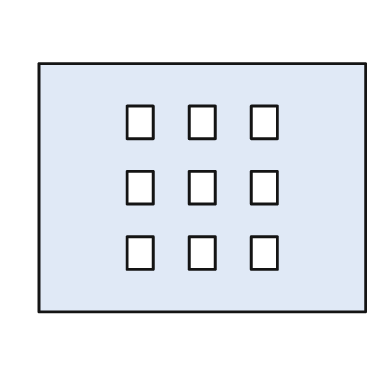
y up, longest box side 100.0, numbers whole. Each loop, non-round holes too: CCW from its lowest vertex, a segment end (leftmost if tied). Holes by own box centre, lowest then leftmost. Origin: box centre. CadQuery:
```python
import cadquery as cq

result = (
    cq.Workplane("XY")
    .moveTo(-50.0, -38.0)
    .lineTo(50.0, -38.0)
    .lineTo(50.0, 38.0)
    .lineTo(-50.0, 38.0)
    .close()
    .moveTo(-23.0, -25.0)
    .lineTo(-15.0, -25.0)
    .lineTo(-15.0, -15.0)
    .lineTo(-23.0, -15.0)
    .close()
    .moveTo(-4.0, -25.0)
    .lineTo(4.0, -25.0)
    .lineTo(4.0, -15.0)
    .lineTo(-4.0, -15.0)
    .close()
    .moveTo(15.0, -25.0)
    .lineTo(23.0, -25.0)
    .lineTo(23.0, -15.0)
    .lineTo(15.0, -15.0)
    .close()
    .moveTo(-23.0, -5.0)
    .lineTo(-15.0, -5.0)
    .lineTo(-15.0, 5.0)
    .lineTo(-23.0, 5.0)
    .close()
    .moveTo(-4.0, -5.0)
    .lineTo(4.0, -5.0)
    .lineTo(4.0, 5.0)
    .lineTo(-4.0, 5.0)
    .close()
    .moveTo(15.0, -5.0)
    .lineTo(23.0, -5.0)
    .lineTo(23.0, 5.0)
    .lineTo(15.0, 5.0)
    .close()
    .moveTo(-23.0, 15.0)
    .lineTo(-15.0, 15.0)
    .lineTo(-15.0, 25.0)
    .lineTo(-23.0, 25.0)
    .close()
    .moveTo(-4.0, 15.0)
    .lineTo(4.0, 15.0)
    .lineTo(4.0, 25.0)
    .lineTo(-4.0, 25.0)
    .close()
    .moveTo(15.0, 15.0)
    .lineTo(23.0, 15.0)
    .lineTo(23.0, 25.0)
    .lineTo(15.0, 25.0)
    .close()
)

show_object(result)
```